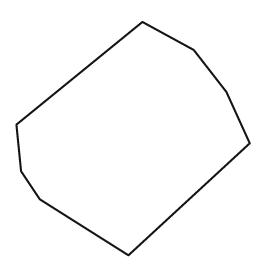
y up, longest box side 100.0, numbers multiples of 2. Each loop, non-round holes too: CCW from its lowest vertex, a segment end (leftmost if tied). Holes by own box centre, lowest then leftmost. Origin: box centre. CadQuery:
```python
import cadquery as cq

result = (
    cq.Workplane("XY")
    .moveTo(-2.0, -50.0)
    .lineTo(50.0, -2.0)
    .lineTo(40.0, 20.0)
    .lineTo(26.0, 38.0)
    .lineTo(4.0, 50.0)
    .lineTo(-50.0, 6.0)
    .lineTo(-48.0, -14.0)
    .lineTo(-40.0, -26.0)
    .close()
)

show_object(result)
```